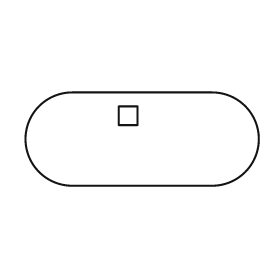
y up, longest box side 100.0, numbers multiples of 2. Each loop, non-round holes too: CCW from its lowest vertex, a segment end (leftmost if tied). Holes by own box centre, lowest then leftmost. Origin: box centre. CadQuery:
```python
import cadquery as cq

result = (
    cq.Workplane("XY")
    .moveTo(-30.0, -20.0)
    .lineTo(30.0, -20.0)
    .threePointArc((50.0, 0.0), (30.0, 20.0))
    .lineTo(-30.0, 20.0)
    .threePointArc((-50.0, 0.0), (-30.0, -20.0))
    .close()
    .moveTo(-10.0, 6.0)
    .lineTo(-2.0, 6.0)
    .lineTo(-2.0, 14.0)
    .lineTo(-10.0, 14.0)
    .close()
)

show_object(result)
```